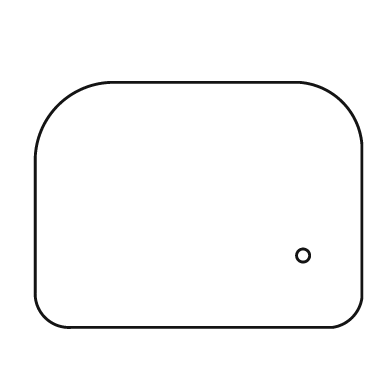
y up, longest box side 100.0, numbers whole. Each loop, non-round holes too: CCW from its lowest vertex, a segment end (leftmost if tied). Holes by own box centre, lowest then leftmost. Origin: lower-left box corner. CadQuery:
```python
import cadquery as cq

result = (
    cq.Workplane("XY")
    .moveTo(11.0, 0.0)
    .lineTo(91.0, 0.0)
    .threePointArc((97.0, 3.0), (100.0, 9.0))
    .lineTo(100.0, 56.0)
    .threePointArc((94.0, 69.0), (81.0, 75.0))
    .lineTo(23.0, 75.0)
    .threePointArc((7.0, 68.0), (0.0, 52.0))
    .lineTo(0.0, 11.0)
    .threePointArc((3.0, 3.0), (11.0, 0.0))
    .close()
    .moveTo(82.0, 22.0)
    .circle(2.0)
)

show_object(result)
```